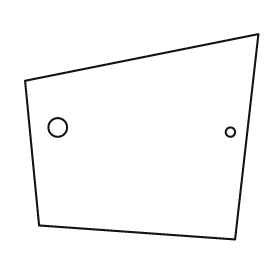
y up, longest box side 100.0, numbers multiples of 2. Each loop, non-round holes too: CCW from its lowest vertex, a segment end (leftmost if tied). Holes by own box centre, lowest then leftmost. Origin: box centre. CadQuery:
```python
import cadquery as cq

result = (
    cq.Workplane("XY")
    .moveTo(40.0, -44.0)
    .lineTo(50.0, 44.0)
    .lineTo(-50.0, 24.0)
    .lineTo(-44.0, -38.0)
    .close()
    .moveTo(38.0, 2.0)
    .circle(2.0)
    .moveTo(-36.0, 4.0)
    .circle(4.0)
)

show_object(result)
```